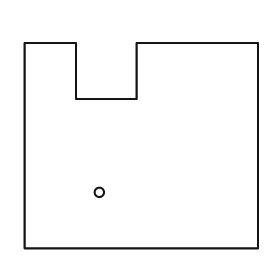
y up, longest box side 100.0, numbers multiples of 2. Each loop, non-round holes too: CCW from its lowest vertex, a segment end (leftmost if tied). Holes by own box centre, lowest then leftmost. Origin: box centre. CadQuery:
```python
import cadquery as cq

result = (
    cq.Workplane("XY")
    .moveTo(-50.0, -44.0)
    .lineTo(50.0, -44.0)
    .lineTo(50.0, 44.0)
    .lineTo(-2.0, 44.0)
    .lineTo(-2.0, 20.0)
    .lineTo(-28.0, 20.0)
    .lineTo(-28.0, 44.0)
    .lineTo(-50.0, 44.0)
    .close()
    .moveTo(-18.0, -20.0)
    .circle(2.0)
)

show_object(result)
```